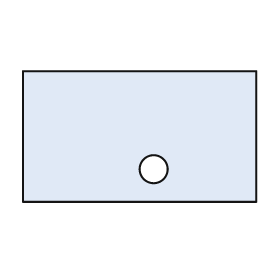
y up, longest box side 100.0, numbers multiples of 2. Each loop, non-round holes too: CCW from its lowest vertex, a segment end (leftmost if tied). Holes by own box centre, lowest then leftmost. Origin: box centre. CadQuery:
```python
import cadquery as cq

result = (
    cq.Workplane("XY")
    .moveTo(-50.0, -28.0)
    .lineTo(50.0, -28.0)
    .lineTo(50.0, 28.0)
    .lineTo(-50.0, 28.0)
    .close()
    .moveTo(6.0, -14.0)
    .circle(6.0)
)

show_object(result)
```